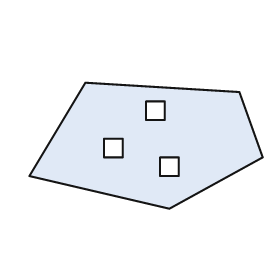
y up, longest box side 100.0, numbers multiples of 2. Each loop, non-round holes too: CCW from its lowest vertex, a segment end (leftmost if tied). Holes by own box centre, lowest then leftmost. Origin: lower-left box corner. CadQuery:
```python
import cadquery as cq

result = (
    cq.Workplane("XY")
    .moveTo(60.0, 0.0)
    .lineTo(100.0, 22.0)
    .lineTo(90.0, 50.0)
    .lineTo(24.0, 54.0)
    .lineTo(0.0, 14.0)
    .close()
    .moveTo(56.0, 14.0)
    .lineTo(64.0, 14.0)
    .lineTo(64.0, 22.0)
    .lineTo(56.0, 22.0)
    .close()
    .moveTo(32.0, 22.0)
    .lineTo(40.0, 22.0)
    .lineTo(40.0, 30.0)
    .lineTo(32.0, 30.0)
    .close()
    .moveTo(50.0, 38.0)
    .lineTo(58.0, 38.0)
    .lineTo(58.0, 46.0)
    .lineTo(50.0, 46.0)
    .close()
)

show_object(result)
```